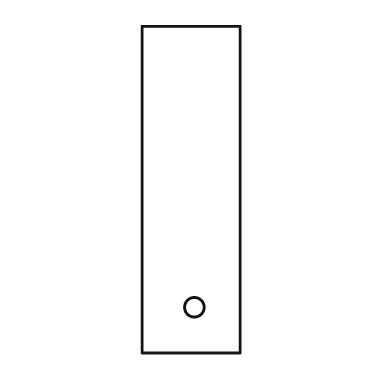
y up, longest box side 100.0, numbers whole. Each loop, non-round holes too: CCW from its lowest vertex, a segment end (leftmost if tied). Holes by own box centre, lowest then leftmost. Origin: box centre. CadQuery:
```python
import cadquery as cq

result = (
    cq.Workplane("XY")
    .moveTo(-15.0, -50.0)
    .lineTo(15.0, -50.0)
    .lineTo(15.0, 50.0)
    .lineTo(-15.0, 50.0)
    .close()
    .moveTo(1.0, -36.0)
    .circle(3.0)
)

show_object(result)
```